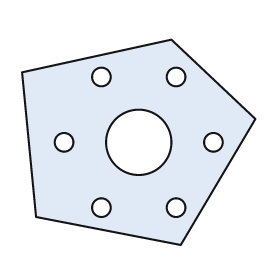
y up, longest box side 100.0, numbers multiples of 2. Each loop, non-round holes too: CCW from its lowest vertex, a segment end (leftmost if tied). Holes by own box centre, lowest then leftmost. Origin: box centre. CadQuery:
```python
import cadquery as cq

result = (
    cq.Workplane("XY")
    .moveTo(18.0, -44.0)
    .lineTo(50.0, 10.0)
    .lineTo(14.0, 44.0)
    .lineTo(-50.0, 30.0)
    .lineTo(-44.0, -32.0)
    .close()
    .moveTo(-16.0, -28.0)
    .circle(4.0)
    .moveTo(16.0, -28.0)
    .circle(4.0)
    .moveTo(-32.0, 0.0)
    .circle(4.0)
    .moveTo(0.0, 0.0)
    .circle(14.0)
    .moveTo(32.0, 0.0)
    .circle(4.0)
    .moveTo(-16.0, 28.0)
    .circle(4.0)
    .moveTo(16.0, 28.0)
    .circle(4.0)
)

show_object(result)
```